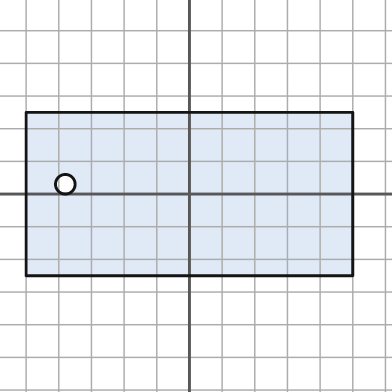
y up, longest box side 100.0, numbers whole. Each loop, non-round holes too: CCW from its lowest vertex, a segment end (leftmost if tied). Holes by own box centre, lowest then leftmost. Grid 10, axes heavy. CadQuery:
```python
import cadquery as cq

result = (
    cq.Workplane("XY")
    .moveTo(-50.0, -25.0)
    .lineTo(50.0, -25.0)
    .lineTo(50.0, 25.0)
    .lineTo(-50.0, 25.0)
    .close()
    .moveTo(-38.0, 3.0)
    .circle(3.0)
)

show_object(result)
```